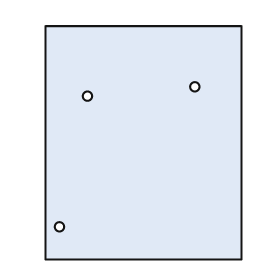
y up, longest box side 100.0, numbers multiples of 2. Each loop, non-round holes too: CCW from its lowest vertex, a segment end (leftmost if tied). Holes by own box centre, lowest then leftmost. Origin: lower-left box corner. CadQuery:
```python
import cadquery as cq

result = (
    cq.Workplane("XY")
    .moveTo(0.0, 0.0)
    .lineTo(84.0, 0.0)
    .lineTo(84.0, 100.0)
    .lineTo(0.0, 100.0)
    .close()
    .moveTo(6.0, 14.0)
    .circle(2.0)
    .moveTo(18.0, 70.0)
    .circle(2.0)
    .moveTo(64.0, 74.0)
    .circle(2.0)
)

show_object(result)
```